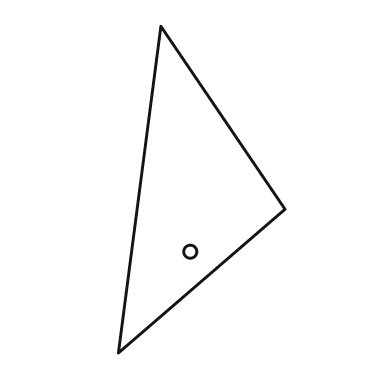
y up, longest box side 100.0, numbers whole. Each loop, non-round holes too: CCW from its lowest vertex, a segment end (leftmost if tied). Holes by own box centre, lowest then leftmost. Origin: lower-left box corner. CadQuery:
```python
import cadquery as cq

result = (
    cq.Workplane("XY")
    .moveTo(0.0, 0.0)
    .lineTo(51.0, 44.0)
    .lineTo(13.0, 100.0)
    .close()
    .moveTo(22.0, 31.0)
    .circle(2.0)
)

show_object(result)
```